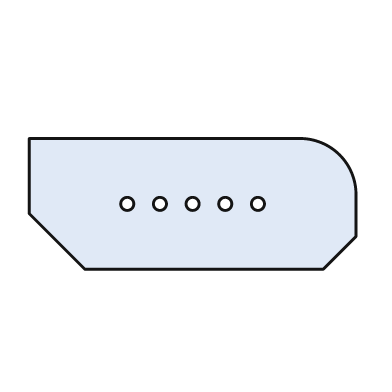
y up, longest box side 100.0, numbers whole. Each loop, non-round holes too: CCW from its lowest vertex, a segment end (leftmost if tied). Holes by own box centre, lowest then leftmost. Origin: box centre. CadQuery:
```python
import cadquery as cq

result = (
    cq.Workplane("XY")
    .moveTo(-33.0, -20.0)
    .lineTo(40.0, -20.0)
    .lineTo(50.0, -10.0)
    .lineTo(50.0, 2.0)
    .threePointArc((45.0, 15.0), (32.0, 20.0))
    .lineTo(-50.0, 20.0)
    .lineTo(-50.0, -3.0)
    .close()
    .moveTo(-20.0, 0.0)
    .circle(2.0)
    .moveTo(-10.0, 0.0)
    .circle(2.0)
    .moveTo(0.0, 0.0)
    .circle(2.0)
    .moveTo(10.0, 0.0)
    .circle(2.0)
    .moveTo(20.0, 0.0)
    .circle(2.0)
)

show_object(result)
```